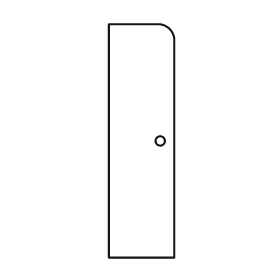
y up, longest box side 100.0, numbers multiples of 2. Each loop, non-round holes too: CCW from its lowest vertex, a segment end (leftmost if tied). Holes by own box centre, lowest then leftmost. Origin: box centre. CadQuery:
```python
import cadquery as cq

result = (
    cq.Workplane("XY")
    .moveTo(-14.0, -50.0)
    .lineTo(14.0, -50.0)
    .lineTo(14.0, 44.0)
    .threePointArc((12.0, 48.0), (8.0, 50.0))
    .lineTo(-14.0, 50.0)
    .close()
    .moveTo(8.0, 0.0)
    .circle(2.0)
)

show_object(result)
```